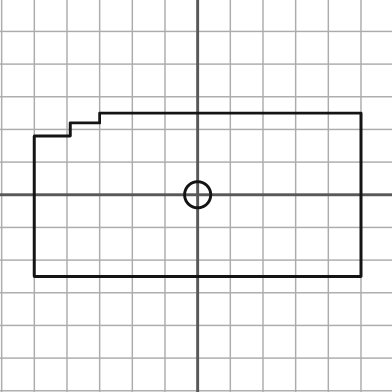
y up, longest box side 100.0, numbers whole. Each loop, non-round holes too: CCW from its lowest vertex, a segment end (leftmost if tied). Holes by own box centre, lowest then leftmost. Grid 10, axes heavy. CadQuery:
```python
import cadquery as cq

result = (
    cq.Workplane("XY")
    .moveTo(-50.0, -25.0)
    .lineTo(50.0, -25.0)
    .lineTo(50.0, 25.0)
    .lineTo(-30.0, 25.0)
    .lineTo(-30.0, 22.0)
    .lineTo(-39.0, 22.0)
    .lineTo(-39.0, 18.0)
    .lineTo(-50.0, 18.0)
    .close()
    .moveTo(0.0, 0.0)
    .circle(4.0)
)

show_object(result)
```